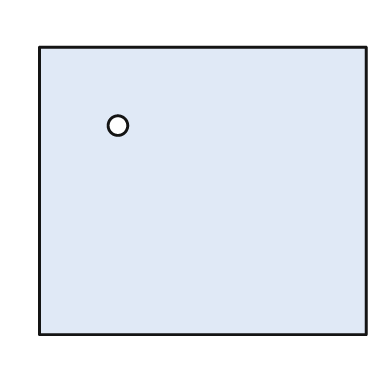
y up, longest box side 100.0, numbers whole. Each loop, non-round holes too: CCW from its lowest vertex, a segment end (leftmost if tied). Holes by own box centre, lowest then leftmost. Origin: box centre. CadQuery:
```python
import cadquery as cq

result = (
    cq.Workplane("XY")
    .moveTo(-50.0, -44.0)
    .lineTo(50.0, -44.0)
    .lineTo(50.0, 44.0)
    .lineTo(-50.0, 44.0)
    .close()
    .moveTo(-26.0, 20.0)
    .circle(3.0)
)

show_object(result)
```